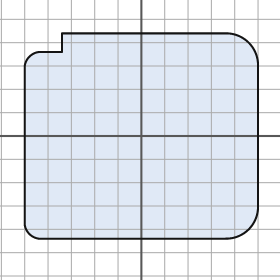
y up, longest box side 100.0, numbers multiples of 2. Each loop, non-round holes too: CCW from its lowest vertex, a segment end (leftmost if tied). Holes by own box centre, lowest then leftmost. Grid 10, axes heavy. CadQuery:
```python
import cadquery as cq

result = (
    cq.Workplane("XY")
    .moveTo(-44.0, -44.0)
    .lineTo(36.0, -44.0)
    .threePointArc((46.0, -40.0), (50.0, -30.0))
    .lineTo(50.0, 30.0)
    .threePointArc((46.0, 40.0), (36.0, 44.0))
    .lineTo(-34.0, 44.0)
    .lineTo(-34.0, 36.0)
    .lineTo(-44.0, 36.0)
    .threePointArc((-48.0, 34.0), (-50.0, 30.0))
    .lineTo(-50.0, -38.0)
    .threePointArc((-48.0, -42.0), (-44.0, -44.0))
    .close()
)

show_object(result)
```